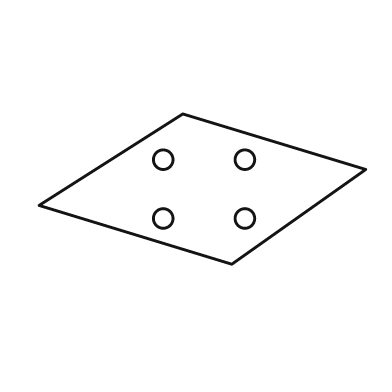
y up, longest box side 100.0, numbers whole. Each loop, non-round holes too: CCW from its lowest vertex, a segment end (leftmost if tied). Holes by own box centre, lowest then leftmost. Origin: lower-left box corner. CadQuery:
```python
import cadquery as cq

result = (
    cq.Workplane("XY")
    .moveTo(59.0, 0.0)
    .lineTo(100.0, 29.0)
    .lineTo(44.0, 46.0)
    .lineTo(0.0, 18.0)
    .close()
    .moveTo(38.0, 14.0)
    .circle(3.0)
    .moveTo(63.0, 14.0)
    .circle(3.0)
    .moveTo(38.0, 32.0)
    .circle(3.0)
    .moveTo(63.0, 32.0)
    .circle(3.0)
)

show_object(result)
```